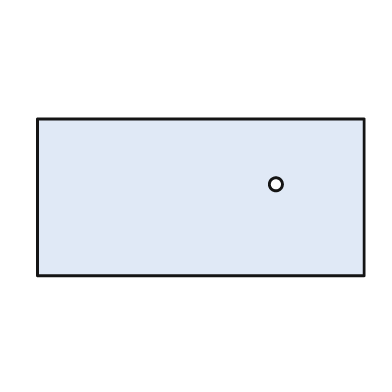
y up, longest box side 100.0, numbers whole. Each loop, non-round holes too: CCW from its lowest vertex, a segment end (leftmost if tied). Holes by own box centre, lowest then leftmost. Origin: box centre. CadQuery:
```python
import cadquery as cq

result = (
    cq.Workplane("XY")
    .moveTo(-50.0, -24.0)
    .lineTo(50.0, -24.0)
    .lineTo(50.0, 24.0)
    .lineTo(-50.0, 24.0)
    .close()
    .moveTo(23.0, 4.0)
    .circle(2.0)
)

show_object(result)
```